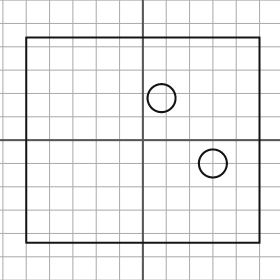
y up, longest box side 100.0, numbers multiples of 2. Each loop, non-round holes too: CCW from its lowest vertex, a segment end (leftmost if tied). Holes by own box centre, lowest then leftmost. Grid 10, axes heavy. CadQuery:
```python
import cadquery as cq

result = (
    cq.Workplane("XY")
    .moveTo(-50.0, -44.0)
    .lineTo(50.0, -44.0)
    .lineTo(50.0, 44.0)
    .lineTo(-50.0, 44.0)
    .close()
    .moveTo(30.0, -10.0)
    .circle(6.0)
    .moveTo(8.0, 18.0)
    .circle(6.0)
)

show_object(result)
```